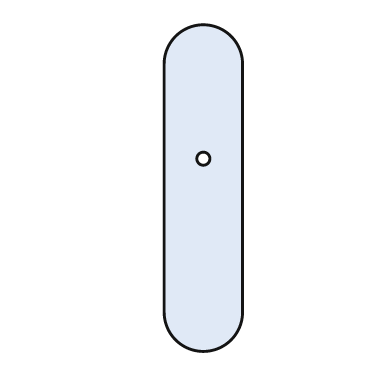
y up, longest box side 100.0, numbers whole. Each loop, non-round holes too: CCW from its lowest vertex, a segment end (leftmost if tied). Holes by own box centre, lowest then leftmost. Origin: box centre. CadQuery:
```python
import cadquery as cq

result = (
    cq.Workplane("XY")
    .moveTo(-12.0, -38.0)
    .threePointArc((0.0, -50.0), (12.0, -38.0))
    .lineTo(12.0, 38.0)
    .threePointArc((0.0, 50.0), (-12.0, 38.0))
    .close()
    .moveTo(0.0, 9.0)
    .circle(2.0)
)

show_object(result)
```